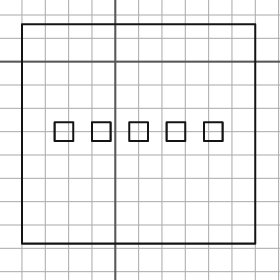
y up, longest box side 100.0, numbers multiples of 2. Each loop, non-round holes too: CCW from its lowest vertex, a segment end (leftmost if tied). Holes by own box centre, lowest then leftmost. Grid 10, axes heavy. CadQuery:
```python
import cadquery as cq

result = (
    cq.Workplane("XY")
    .moveTo(-40.0, -78.0)
    .lineTo(60.0, -78.0)
    .lineTo(60.0, 16.0)
    .lineTo(-40.0, 16.0)
    .close()
    .moveTo(-26.0, -34.0)
    .lineTo(-18.0, -34.0)
    .lineTo(-18.0, -26.0)
    .lineTo(-26.0, -26.0)
    .close()
    .moveTo(-10.0, -34.0)
    .lineTo(-2.0, -34.0)
    .lineTo(-2.0, -26.0)
    .lineTo(-10.0, -26.0)
    .close()
    .moveTo(6.0, -34.0)
    .lineTo(14.0, -34.0)
    .lineTo(14.0, -26.0)
    .lineTo(6.0, -26.0)
    .close()
    .moveTo(22.0, -34.0)
    .lineTo(30.0, -34.0)
    .lineTo(30.0, -26.0)
    .lineTo(22.0, -26.0)
    .close()
    .moveTo(38.0, -34.0)
    .lineTo(46.0, -34.0)
    .lineTo(46.0, -26.0)
    .lineTo(38.0, -26.0)
    .close()
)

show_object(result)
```